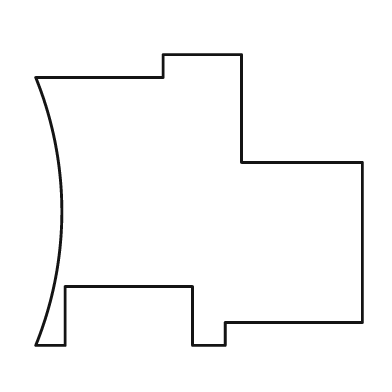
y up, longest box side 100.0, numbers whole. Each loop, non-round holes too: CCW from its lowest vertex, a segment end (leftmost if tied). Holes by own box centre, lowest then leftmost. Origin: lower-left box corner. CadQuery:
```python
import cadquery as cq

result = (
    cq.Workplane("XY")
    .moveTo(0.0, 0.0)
    .lineTo(9.0, 0.0)
    .lineTo(9.0, 18.0)
    .lineTo(48.0, 18.0)
    .lineTo(48.0, 0.0)
    .lineTo(58.0, 0.0)
    .lineTo(58.0, 7.0)
    .lineTo(100.0, 7.0)
    .lineTo(100.0, 56.0)
    .lineTo(63.0, 56.0)
    .lineTo(63.0, 89.0)
    .lineTo(39.0, 89.0)
    .lineTo(39.0, 82.0)
    .lineTo(0.0, 82.0)
    .threePointArc((8.0, 41.0), (0.0, 0.0))
    .close()
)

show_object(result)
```